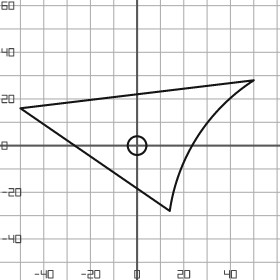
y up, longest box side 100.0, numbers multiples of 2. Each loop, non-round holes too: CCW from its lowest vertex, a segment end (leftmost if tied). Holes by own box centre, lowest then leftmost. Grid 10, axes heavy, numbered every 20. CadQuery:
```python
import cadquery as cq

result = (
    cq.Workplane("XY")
    .moveTo(14.0, -28.0)
    .threePointArc((26.0, 4.0), (50.0, 28.0))
    .lineTo(-50.0, 16.0)
    .close()
    .moveTo(0.0, 0.0)
    .circle(4.0)
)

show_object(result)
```